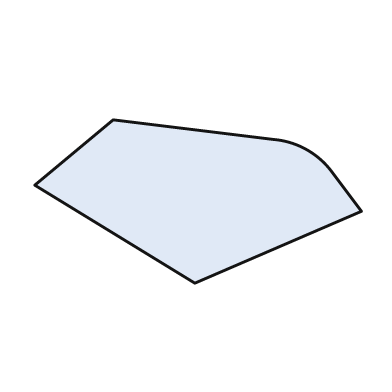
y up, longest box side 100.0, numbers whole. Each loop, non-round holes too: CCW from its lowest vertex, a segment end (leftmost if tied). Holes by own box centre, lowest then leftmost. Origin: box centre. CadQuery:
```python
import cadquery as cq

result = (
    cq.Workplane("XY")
    .moveTo(-1.0, -25.0)
    .lineTo(50.0, -3.0)
    .lineTo(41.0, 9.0)
    .threePointArc((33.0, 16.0), (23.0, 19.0))
    .lineTo(-26.0, 25.0)
    .lineTo(-50.0, 5.0)
    .close()
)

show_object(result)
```